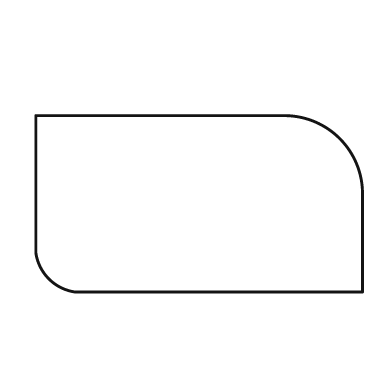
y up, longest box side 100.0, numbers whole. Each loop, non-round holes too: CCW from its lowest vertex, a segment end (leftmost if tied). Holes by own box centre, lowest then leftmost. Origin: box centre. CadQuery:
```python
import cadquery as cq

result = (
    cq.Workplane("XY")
    .moveTo(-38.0, -27.0)
    .lineTo(50.0, -27.0)
    .lineTo(50.0, 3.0)
    .threePointArc((43.0, 20.0), (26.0, 27.0))
    .lineTo(-50.0, 27.0)
    .lineTo(-50.0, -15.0)
    .threePointArc((-46.0, -23.0), (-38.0, -27.0))
    .close()
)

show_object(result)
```